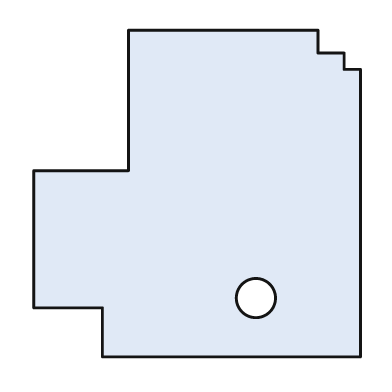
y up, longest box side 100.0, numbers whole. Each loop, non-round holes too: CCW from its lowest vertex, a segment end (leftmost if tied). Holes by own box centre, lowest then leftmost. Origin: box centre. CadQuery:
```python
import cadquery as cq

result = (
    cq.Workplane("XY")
    .moveTo(-29.0, -50.0)
    .lineTo(50.0, -50.0)
    .lineTo(50.0, 38.0)
    .lineTo(45.0, 38.0)
    .lineTo(45.0, 43.0)
    .lineTo(37.0, 43.0)
    .lineTo(37.0, 50.0)
    .lineTo(-21.0, 50.0)
    .lineTo(-21.0, 7.0)
    .lineTo(-50.0, 7.0)
    .lineTo(-50.0, -35.0)
    .lineTo(-29.0, -35.0)
    .close()
    .moveTo(18.0, -32.0)
    .circle(6.0)
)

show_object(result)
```